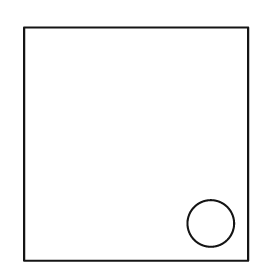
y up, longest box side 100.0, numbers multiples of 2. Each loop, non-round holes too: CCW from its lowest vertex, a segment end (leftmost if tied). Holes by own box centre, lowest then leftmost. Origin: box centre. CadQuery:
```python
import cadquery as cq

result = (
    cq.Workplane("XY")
    .moveTo(-48.0, -50.0)
    .lineTo(48.0, -50.0)
    .lineTo(48.0, 50.0)
    .lineTo(-48.0, 50.0)
    .close()
    .moveTo(32.0, -34.0)
    .circle(10.0)
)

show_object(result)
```